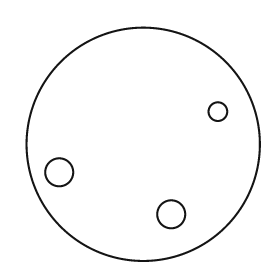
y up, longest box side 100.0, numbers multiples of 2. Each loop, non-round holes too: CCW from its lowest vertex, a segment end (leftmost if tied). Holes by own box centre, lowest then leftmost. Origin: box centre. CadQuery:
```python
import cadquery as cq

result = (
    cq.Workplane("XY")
    .moveTo(0.0, 0.0)
    .circle(50.0)
    .moveTo(12.0, -30.0)
    .circle(6.0)
    .moveTo(-36.0, -12.0)
    .circle(6.0)
    .moveTo(32.0, 14.0)
    .circle(4.0)
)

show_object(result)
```